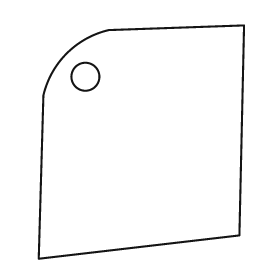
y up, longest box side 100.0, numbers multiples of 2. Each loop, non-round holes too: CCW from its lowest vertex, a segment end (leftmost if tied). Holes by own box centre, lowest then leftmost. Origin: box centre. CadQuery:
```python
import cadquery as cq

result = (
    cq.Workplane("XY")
    .moveTo(-44.0, -50.0)
    .lineTo(42.0, -40.0)
    .lineTo(44.0, 50.0)
    .lineTo(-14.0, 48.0)
    .threePointArc((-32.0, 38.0), (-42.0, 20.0))
    .close()
    .moveTo(-24.0, 28.0)
    .circle(6.0)
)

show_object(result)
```